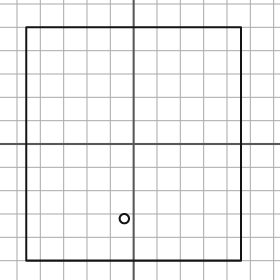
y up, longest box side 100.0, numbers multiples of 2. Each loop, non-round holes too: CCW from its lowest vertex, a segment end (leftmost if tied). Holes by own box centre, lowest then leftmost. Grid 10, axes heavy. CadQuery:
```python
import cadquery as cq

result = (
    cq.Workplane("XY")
    .moveTo(-46.0, -50.0)
    .lineTo(46.0, -50.0)
    .lineTo(46.0, 50.0)
    .lineTo(-46.0, 50.0)
    .close()
    .moveTo(-4.0, -32.0)
    .circle(2.0)
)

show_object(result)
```